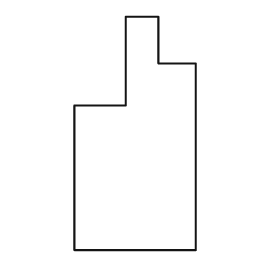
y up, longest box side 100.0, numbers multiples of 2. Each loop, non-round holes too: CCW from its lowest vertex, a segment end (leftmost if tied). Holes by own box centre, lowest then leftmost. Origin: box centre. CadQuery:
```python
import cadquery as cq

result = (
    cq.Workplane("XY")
    .moveTo(-26.0, -50.0)
    .lineTo(26.0, -50.0)
    .lineTo(26.0, 30.0)
    .lineTo(10.0, 30.0)
    .lineTo(10.0, 50.0)
    .lineTo(-4.0, 50.0)
    .lineTo(-4.0, 12.0)
    .lineTo(-26.0, 12.0)
    .close()
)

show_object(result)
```